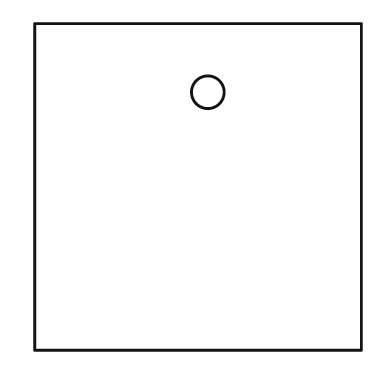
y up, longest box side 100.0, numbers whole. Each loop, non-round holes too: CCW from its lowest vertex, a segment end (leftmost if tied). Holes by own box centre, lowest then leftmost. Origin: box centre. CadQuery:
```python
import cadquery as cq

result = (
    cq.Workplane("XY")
    .moveTo(-50.0, -50.0)
    .lineTo(50.0, -50.0)
    .lineTo(50.0, 50.0)
    .lineTo(-50.0, 50.0)
    .close()
    .moveTo(3.0, 29.0)
    .circle(5.0)
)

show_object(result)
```